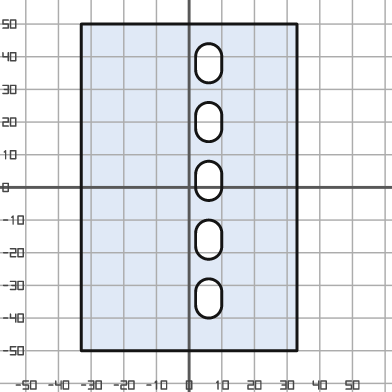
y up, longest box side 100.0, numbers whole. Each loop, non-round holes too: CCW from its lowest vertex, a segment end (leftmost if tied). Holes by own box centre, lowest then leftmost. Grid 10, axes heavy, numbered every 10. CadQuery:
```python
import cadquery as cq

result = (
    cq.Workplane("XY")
    .moveTo(-33.0, -50.0)
    .lineTo(33.0, -50.0)
    .lineTo(33.0, 50.0)
    .lineTo(-33.0, 50.0)
    .close()
    .moveTo(2.0, -36.0)
    .threePointArc((6.0, -40.0), (10.0, -36.0))
    .lineTo(10.0, -32.0)
    .threePointArc((6.0, -28.0), (2.0, -32.0))
    .close()
    .moveTo(2.0, -18.0)
    .threePointArc((6.0, -22.0), (10.0, -18.0))
    .lineTo(10.0, -14.0)
    .threePointArc((6.0, -10.0), (2.0, -14.0))
    .close()
    .moveTo(2.0, 0.0)
    .threePointArc((6.0, -4.0), (10.0, 0.0))
    .lineTo(10.0, 4.0)
    .threePointArc((6.0, 8.0), (2.0, 4.0))
    .close()
    .moveTo(2.0, 18.0)
    .threePointArc((6.0, 14.0), (10.0, 18.0))
    .lineTo(10.0, 22.0)
    .threePointArc((6.0, 26.0), (2.0, 22.0))
    .close()
    .moveTo(2.0, 36.0)
    .threePointArc((6.0, 32.0), (10.0, 36.0))
    .lineTo(10.0, 40.0)
    .threePointArc((6.0, 44.0), (2.0, 40.0))
    .close()
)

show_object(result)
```